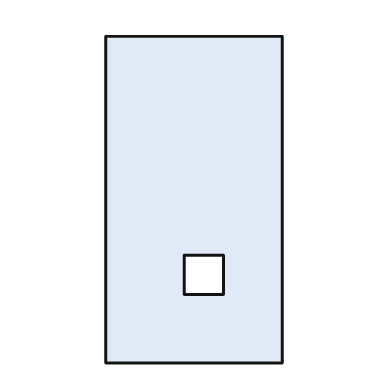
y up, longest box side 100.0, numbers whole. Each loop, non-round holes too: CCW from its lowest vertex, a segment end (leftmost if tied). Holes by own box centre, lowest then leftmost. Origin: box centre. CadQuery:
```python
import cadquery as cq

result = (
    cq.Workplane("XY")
    .moveTo(-27.0, -50.0)
    .lineTo(27.0, -50.0)
    .lineTo(27.0, 50.0)
    .lineTo(-27.0, 50.0)
    .close()
    .moveTo(-3.0, -29.0)
    .lineTo(9.0, -29.0)
    .lineTo(9.0, -17.0)
    .lineTo(-3.0, -17.0)
    .close()
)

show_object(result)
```